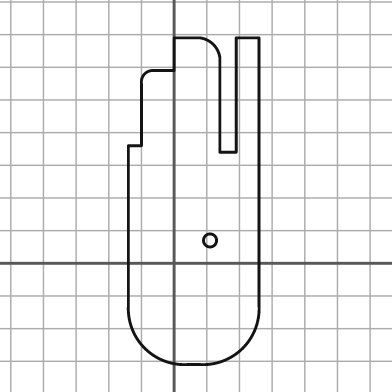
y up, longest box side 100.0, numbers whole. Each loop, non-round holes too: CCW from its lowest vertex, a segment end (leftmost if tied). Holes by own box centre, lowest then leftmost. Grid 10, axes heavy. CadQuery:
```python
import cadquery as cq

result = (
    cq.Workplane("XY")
    .moveTo(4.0, -31.0)
    .lineTo(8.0, -31.0)
    .threePointArc((21.0, -26.0), (26.0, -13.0))
    .lineTo(26.0, 69.0)
    .lineTo(19.0, 69.0)
    .lineTo(19.0, 34.0)
    .lineTo(14.0, 34.0)
    .lineTo(14.0, 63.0)
    .threePointArc((12.0, 67.0), (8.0, 69.0))
    .lineTo(0.0, 69.0)
    .lineTo(0.0, 59.0)
    .lineTo(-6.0, 59.0)
    .threePointArc((-9.0, 58.0), (-10.0, 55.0))
    .lineTo(-10.0, 36.0)
    .lineTo(-14.0, 36.0)
    .lineTo(-14.0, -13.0)
    .threePointArc((-9.0, -26.0), (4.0, -31.0))
    .close()
    .moveTo(11.0, 7.0)
    .circle(2.0)
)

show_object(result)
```